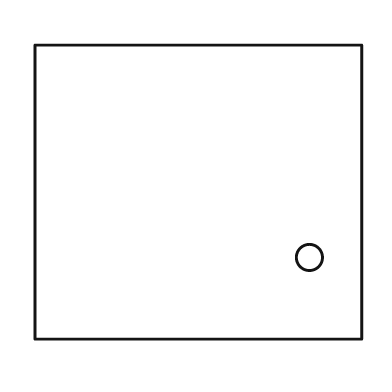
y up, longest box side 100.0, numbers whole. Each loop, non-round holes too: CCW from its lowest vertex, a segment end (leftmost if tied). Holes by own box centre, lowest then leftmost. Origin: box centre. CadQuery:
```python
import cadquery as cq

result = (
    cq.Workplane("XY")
    .moveTo(-50.0, -45.0)
    .lineTo(50.0, -45.0)
    .lineTo(50.0, 45.0)
    .lineTo(-50.0, 45.0)
    .close()
    .moveTo(34.0, -20.0)
    .circle(4.0)
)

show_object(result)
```